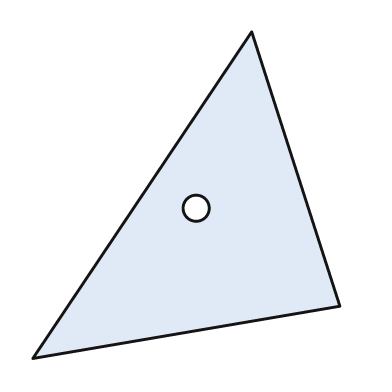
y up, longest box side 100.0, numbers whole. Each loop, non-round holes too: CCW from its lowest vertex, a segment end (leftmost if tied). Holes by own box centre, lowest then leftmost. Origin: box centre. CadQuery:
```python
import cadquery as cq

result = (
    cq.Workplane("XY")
    .moveTo(-47.0, -50.0)
    .lineTo(47.0, -34.0)
    .lineTo(20.0, 50.0)
    .close()
    .moveTo(3.0, -4.0)
    .circle(4.0)
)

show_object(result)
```